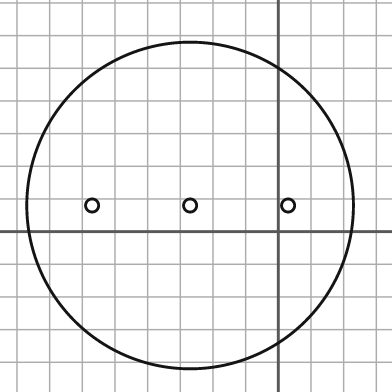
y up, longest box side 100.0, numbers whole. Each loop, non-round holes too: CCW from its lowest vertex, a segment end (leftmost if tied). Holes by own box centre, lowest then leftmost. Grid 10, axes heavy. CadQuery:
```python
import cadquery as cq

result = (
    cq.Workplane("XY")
    .moveTo(-27.0, 8.0)
    .circle(50.0)
    .moveTo(-57.0, 8.0)
    .circle(2.0)
    .moveTo(-27.0, 8.0)
    .circle(2.0)
    .moveTo(3.0, 8.0)
    .circle(2.0)
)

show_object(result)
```